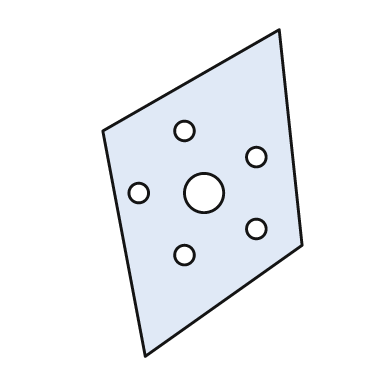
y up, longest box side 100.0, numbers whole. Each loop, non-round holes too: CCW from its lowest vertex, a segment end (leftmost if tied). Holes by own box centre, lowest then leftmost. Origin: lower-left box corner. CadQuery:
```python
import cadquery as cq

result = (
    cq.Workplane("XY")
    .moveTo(13.0, 0.0)
    .lineTo(61.0, 34.0)
    .lineTo(54.0, 100.0)
    .lineTo(0.0, 69.0)
    .close()
    .moveTo(25.0, 31.0)
    .circle(3.0)
    .moveTo(47.0, 39.0)
    .circle(3.0)
    .moveTo(11.0, 50.0)
    .circle(3.0)
    .moveTo(31.0, 50.0)
    .circle(6.0)
    .moveTo(47.0, 61.0)
    .circle(3.0)
    .moveTo(25.0, 69.0)
    .circle(3.0)
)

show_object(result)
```